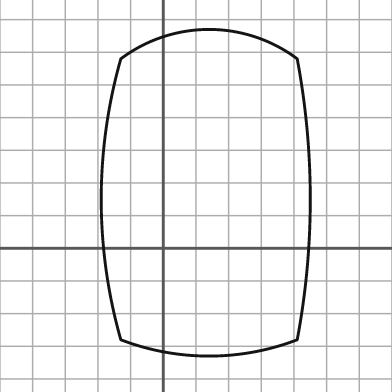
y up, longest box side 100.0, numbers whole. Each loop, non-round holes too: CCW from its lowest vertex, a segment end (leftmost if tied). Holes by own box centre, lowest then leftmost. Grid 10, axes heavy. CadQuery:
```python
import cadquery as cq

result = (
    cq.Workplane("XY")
    .moveTo(-13.0, -28.0)
    .threePointArc((14.0, -33.0), (41.0, -28.0))
    .threePointArc((45.0, 15.0), (41.0, 58.0))
    .threePointArc((14.0, 67.0), (-13.0, 58.0))
    .threePointArc((-19.0, 15.0), (-13.0, -28.0))
    .close()
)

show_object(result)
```